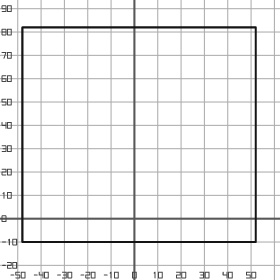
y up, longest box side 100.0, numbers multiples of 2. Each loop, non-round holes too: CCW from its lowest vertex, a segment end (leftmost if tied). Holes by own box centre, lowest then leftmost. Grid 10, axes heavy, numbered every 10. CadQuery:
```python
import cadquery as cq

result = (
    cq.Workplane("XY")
    .moveTo(-48.0, -10.0)
    .lineTo(52.0, -10.0)
    .lineTo(52.0, 82.0)
    .lineTo(-48.0, 82.0)
    .close()
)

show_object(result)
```